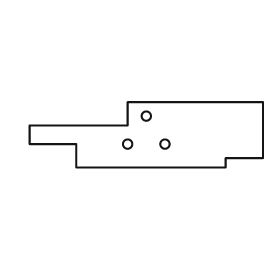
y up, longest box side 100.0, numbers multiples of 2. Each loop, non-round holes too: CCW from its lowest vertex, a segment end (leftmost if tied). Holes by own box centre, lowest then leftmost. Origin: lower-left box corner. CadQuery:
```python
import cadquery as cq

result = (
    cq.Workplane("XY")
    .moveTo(20.0, 0.0)
    .lineTo(84.0, 0.0)
    .lineTo(84.0, 4.0)
    .lineTo(100.0, 4.0)
    .lineTo(100.0, 28.0)
    .lineTo(42.0, 28.0)
    .lineTo(42.0, 18.0)
    .lineTo(0.0, 18.0)
    .lineTo(0.0, 10.0)
    .lineTo(20.0, 10.0)
    .close()
    .moveTo(42.0, 10.0)
    .circle(2.0)
    .moveTo(58.0, 10.0)
    .circle(2.0)
    .moveTo(50.0, 22.0)
    .circle(2.0)
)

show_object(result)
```